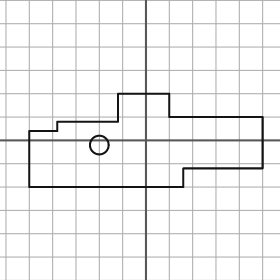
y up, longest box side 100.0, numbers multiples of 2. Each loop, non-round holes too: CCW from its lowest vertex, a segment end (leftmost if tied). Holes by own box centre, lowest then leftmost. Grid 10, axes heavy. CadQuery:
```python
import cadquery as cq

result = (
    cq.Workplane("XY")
    .moveTo(-50.0, -20.0)
    .lineTo(16.0, -20.0)
    .lineTo(16.0, -12.0)
    .lineTo(50.0, -12.0)
    .lineTo(50.0, 10.0)
    .lineTo(10.0, 10.0)
    .lineTo(10.0, 20.0)
    .lineTo(-12.0, 20.0)
    .lineTo(-12.0, 8.0)
    .lineTo(-38.0, 8.0)
    .lineTo(-38.0, 4.0)
    .lineTo(-50.0, 4.0)
    .close()
    .moveTo(-20.0, -2.0)
    .circle(4.0)
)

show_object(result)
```